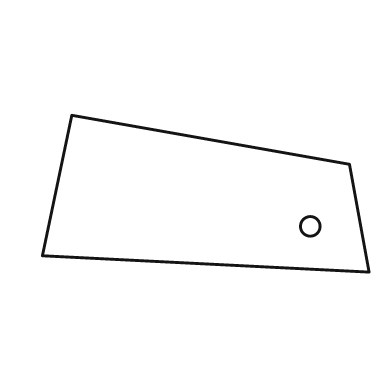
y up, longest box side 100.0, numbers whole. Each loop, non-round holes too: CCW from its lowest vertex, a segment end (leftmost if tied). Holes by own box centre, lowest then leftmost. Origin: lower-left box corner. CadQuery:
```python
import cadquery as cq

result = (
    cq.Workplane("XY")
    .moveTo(100.0, 0.0)
    .lineTo(94.0, 33.0)
    .lineTo(9.0, 48.0)
    .lineTo(0.0, 5.0)
    .close()
    .moveTo(82.0, 14.0)
    .circle(3.0)
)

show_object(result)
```